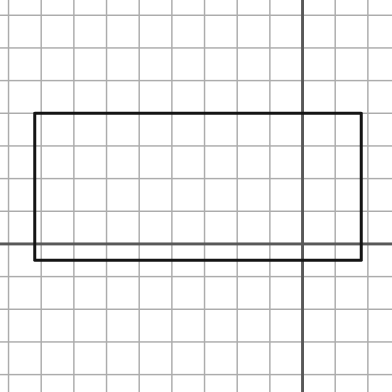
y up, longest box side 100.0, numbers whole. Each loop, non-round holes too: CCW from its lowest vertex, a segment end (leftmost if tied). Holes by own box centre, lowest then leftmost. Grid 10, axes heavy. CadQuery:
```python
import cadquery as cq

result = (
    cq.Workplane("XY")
    .moveTo(-82.0, -5.0)
    .lineTo(18.0, -5.0)
    .lineTo(18.0, 40.0)
    .lineTo(-82.0, 40.0)
    .close()
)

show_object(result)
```